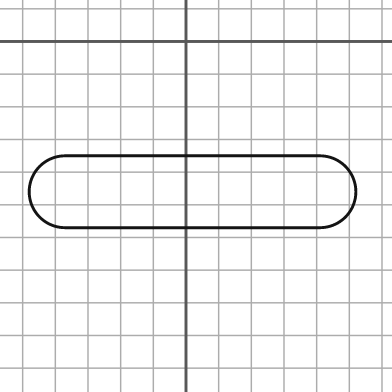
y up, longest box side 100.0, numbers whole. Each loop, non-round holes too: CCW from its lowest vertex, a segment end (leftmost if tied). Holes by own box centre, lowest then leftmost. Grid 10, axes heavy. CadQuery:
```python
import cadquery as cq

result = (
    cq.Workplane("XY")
    .moveTo(-37.0, -57.0)
    .lineTo(41.0, -57.0)
    .threePointArc((52.0, -46.0), (41.0, -35.0))
    .lineTo(-37.0, -35.0)
    .threePointArc((-48.0, -46.0), (-37.0, -57.0))
    .close()
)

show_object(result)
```